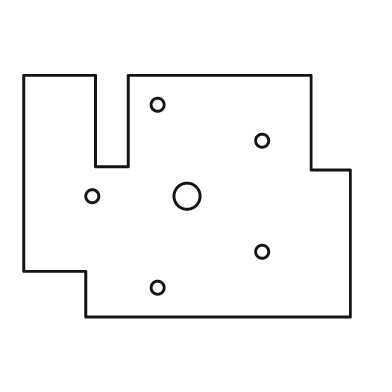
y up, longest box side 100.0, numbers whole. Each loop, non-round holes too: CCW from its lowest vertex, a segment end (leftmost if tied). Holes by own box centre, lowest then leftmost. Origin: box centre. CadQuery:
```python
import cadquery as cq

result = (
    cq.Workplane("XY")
    .moveTo(-31.0, -37.0)
    .lineTo(50.0, -37.0)
    .lineTo(50.0, 8.0)
    .lineTo(38.0, 8.0)
    .lineTo(38.0, 37.0)
    .lineTo(-18.0, 37.0)
    .lineTo(-18.0, 9.0)
    .lineTo(-28.0, 9.0)
    .lineTo(-28.0, 37.0)
    .lineTo(-50.0, 37.0)
    .lineTo(-50.0, -23.0)
    .lineTo(-31.0, -23.0)
    .close()
    .moveTo(-9.0, -28.0)
    .circle(2.0)
    .moveTo(23.0, -17.0)
    .circle(2.0)
    .moveTo(-29.0, 0.0)
    .circle(2.0)
    .moveTo(0.0, 0.0)
    .circle(4.0)
    .moveTo(23.0, 17.0)
    .circle(2.0)
    .moveTo(-9.0, 28.0)
    .circle(2.0)
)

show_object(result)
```